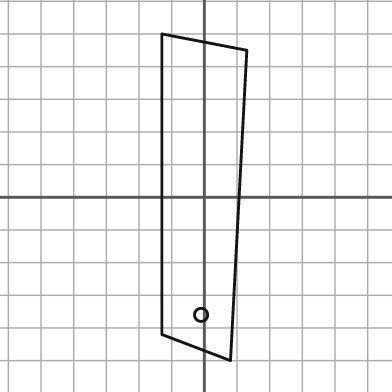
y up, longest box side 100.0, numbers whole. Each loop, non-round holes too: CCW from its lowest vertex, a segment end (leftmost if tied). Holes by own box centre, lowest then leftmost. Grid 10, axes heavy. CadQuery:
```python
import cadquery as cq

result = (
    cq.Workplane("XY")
    .moveTo(8.0, -50.0)
    .lineTo(13.0, 45.0)
    .lineTo(-13.0, 50.0)
    .lineTo(-13.0, -42.0)
    .close()
    .moveTo(-1.0, -36.0)
    .circle(2.0)
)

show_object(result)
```